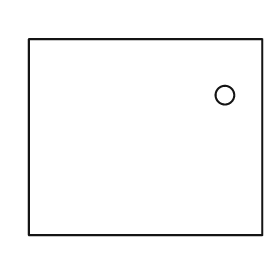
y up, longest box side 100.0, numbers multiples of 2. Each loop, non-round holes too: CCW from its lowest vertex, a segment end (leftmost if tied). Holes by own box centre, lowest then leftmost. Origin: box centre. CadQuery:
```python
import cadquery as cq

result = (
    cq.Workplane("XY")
    .moveTo(-50.0, -42.0)
    .lineTo(50.0, -42.0)
    .lineTo(50.0, 42.0)
    .lineTo(-50.0, 42.0)
    .close()
    .moveTo(34.0, 18.0)
    .circle(4.0)
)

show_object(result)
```